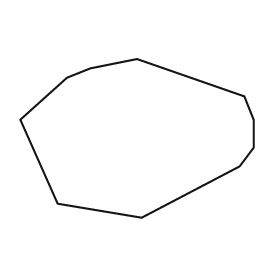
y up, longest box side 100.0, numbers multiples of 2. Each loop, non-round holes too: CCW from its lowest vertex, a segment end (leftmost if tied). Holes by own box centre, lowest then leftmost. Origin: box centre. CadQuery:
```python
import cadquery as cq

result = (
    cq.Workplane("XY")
    .moveTo(2.0, -34.0)
    .lineTo(44.0, -12.0)
    .lineTo(50.0, -4.0)
    .lineTo(50.0, 8.0)
    .lineTo(46.0, 18.0)
    .lineTo(0.0, 34.0)
    .lineTo(-20.0, 30.0)
    .lineTo(-30.0, 26.0)
    .lineTo(-50.0, 8.0)
    .lineTo(-34.0, -28.0)
    .close()
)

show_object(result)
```